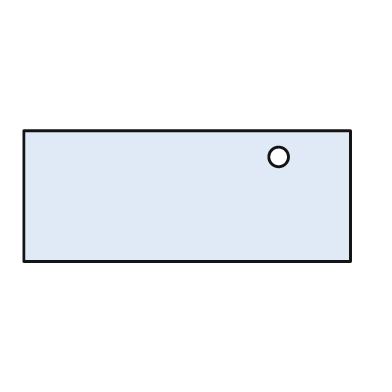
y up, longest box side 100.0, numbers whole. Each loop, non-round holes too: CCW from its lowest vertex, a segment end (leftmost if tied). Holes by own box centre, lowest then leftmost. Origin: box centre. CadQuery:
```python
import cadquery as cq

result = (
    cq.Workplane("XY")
    .moveTo(-50.0, -20.0)
    .lineTo(50.0, -20.0)
    .lineTo(50.0, 20.0)
    .lineTo(-50.0, 20.0)
    .close()
    .moveTo(28.0, 12.0)
    .circle(3.0)
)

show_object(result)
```